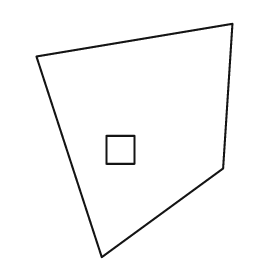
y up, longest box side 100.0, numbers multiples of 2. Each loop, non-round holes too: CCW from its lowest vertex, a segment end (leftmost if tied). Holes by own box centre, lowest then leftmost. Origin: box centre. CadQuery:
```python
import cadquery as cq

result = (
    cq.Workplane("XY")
    .moveTo(-14.0, -50.0)
    .lineTo(38.0, -12.0)
    .lineTo(42.0, 50.0)
    .lineTo(-42.0, 36.0)
    .close()
    .moveTo(-12.0, -10.0)
    .lineTo(0.0, -10.0)
    .lineTo(0.0, 2.0)
    .lineTo(-12.0, 2.0)
    .close()
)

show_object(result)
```